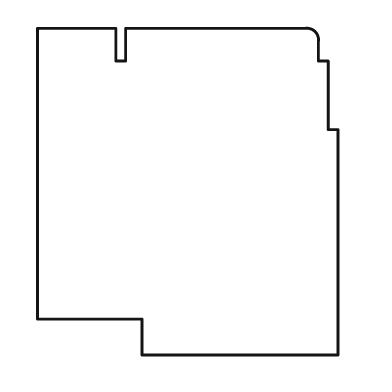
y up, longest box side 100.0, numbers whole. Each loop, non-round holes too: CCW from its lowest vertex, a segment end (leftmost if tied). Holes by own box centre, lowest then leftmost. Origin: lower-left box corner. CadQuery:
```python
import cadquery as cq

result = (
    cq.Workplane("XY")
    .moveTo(32.0, 0.0)
    .lineTo(92.0, 0.0)
    .lineTo(92.0, 69.0)
    .lineTo(89.0, 69.0)
    .lineTo(89.0, 90.0)
    .lineTo(86.0, 90.0)
    .lineTo(86.0, 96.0)
    .threePointArc((85.0, 99.0), (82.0, 100.0))
    .lineTo(27.0, 100.0)
    .lineTo(27.0, 90.0)
    .lineTo(24.0, 90.0)
    .lineTo(24.0, 100.0)
    .lineTo(0.0, 100.0)
    .lineTo(0.0, 11.0)
    .lineTo(32.0, 11.0)
    .close()
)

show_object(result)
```